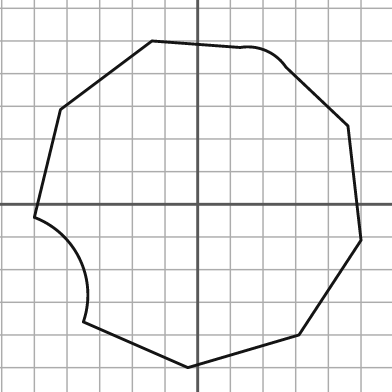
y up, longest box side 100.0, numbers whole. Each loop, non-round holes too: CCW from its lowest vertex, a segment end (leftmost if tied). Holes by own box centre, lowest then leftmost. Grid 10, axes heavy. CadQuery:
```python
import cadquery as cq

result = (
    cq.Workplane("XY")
    .moveTo(-3.0, -50.0)
    .lineTo(31.0, -40.0)
    .lineTo(50.0, -11.0)
    .lineTo(46.0, 24.0)
    .lineTo(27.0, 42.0)
    .threePointArc((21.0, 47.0), (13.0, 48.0))
    .lineTo(-14.0, 50.0)
    .lineTo(-42.0, 29.0)
    .lineTo(-50.0, -4.0)
    .threePointArc((-36.0, -17.0), (-35.0, -36.0))
    .close()
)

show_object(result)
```